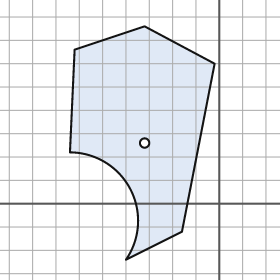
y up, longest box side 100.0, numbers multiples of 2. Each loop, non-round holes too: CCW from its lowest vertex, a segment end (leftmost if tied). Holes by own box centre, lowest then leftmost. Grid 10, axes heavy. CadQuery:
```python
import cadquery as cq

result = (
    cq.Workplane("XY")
    .moveTo(-40.0, -24.0)
    .lineTo(-16.0, -12.0)
    .lineTo(-2.0, 60.0)
    .lineTo(-32.0, 76.0)
    .lineTo(-62.0, 66.0)
    .lineTo(-64.0, 22.0)
    .threePointArc((-38.0, 6.0), (-40.0, -24.0))
    .close()
    .moveTo(-32.0, 26.0)
    .circle(2.0)
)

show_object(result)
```